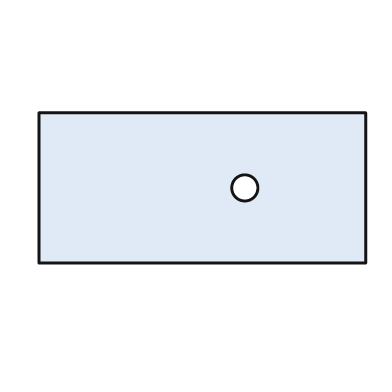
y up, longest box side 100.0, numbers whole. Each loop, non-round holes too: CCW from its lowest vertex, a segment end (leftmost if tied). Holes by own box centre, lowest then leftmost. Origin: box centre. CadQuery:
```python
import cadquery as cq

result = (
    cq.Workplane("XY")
    .moveTo(-50.0, -23.0)
    .lineTo(50.0, -23.0)
    .lineTo(50.0, 23.0)
    .lineTo(-50.0, 23.0)
    .close()
    .moveTo(13.0, 0.0)
    .circle(4.0)
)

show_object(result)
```